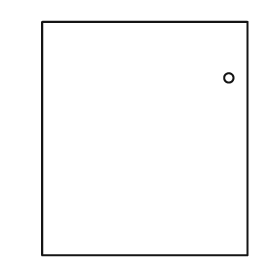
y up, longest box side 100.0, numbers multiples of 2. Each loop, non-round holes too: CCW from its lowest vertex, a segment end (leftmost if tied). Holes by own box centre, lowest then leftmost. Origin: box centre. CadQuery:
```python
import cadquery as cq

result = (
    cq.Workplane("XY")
    .moveTo(-44.0, -50.0)
    .lineTo(44.0, -50.0)
    .lineTo(44.0, 50.0)
    .lineTo(-44.0, 50.0)
    .close()
    .moveTo(36.0, 26.0)
    .circle(2.0)
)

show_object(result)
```